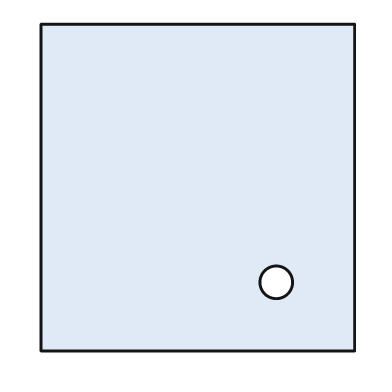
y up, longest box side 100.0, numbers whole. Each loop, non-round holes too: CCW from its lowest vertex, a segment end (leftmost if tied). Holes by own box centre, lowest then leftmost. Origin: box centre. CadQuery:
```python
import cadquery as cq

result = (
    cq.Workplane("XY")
    .moveTo(-48.0, -50.0)
    .lineTo(48.0, -50.0)
    .lineTo(48.0, 50.0)
    .lineTo(-48.0, 50.0)
    .close()
    .moveTo(24.0, -29.0)
    .circle(5.0)
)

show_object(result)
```